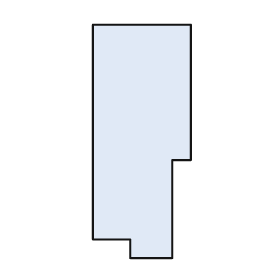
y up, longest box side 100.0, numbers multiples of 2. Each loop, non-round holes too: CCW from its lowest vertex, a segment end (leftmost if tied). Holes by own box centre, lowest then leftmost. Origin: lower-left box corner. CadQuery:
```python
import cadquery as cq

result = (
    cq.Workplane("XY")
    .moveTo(16.0, 0.0)
    .lineTo(34.0, 0.0)
    .lineTo(34.0, 42.0)
    .lineTo(42.0, 42.0)
    .lineTo(42.0, 100.0)
    .lineTo(0.0, 100.0)
    .lineTo(0.0, 8.0)
    .lineTo(16.0, 8.0)
    .close()
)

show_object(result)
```